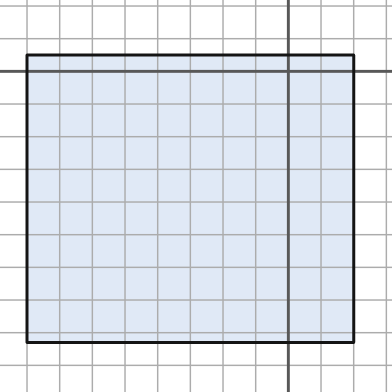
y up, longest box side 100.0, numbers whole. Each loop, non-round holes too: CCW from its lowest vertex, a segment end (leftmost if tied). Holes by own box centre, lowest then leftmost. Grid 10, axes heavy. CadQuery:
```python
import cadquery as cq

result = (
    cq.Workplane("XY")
    .moveTo(-80.0, -83.0)
    .lineTo(20.0, -83.0)
    .lineTo(20.0, 5.0)
    .lineTo(-80.0, 5.0)
    .close()
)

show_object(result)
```